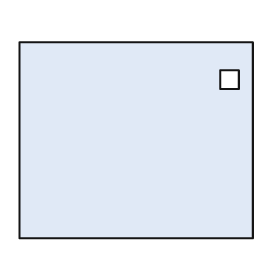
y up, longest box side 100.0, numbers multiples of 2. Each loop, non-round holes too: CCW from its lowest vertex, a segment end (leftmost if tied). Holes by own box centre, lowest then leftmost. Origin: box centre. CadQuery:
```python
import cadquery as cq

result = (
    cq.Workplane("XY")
    .moveTo(-50.0, -42.0)
    .lineTo(50.0, -42.0)
    .lineTo(50.0, 42.0)
    .lineTo(-50.0, 42.0)
    .close()
    .moveTo(36.0, 22.0)
    .lineTo(44.0, 22.0)
    .lineTo(44.0, 30.0)
    .lineTo(36.0, 30.0)
    .close()
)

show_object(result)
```